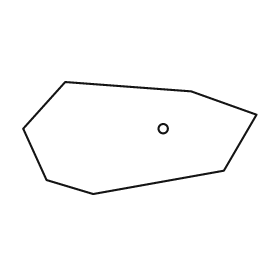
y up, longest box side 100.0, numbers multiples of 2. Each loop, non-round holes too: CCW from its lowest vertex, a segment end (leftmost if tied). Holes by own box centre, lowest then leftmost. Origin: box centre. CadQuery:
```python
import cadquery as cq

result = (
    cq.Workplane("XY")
    .moveTo(-20.0, -24.0)
    .lineTo(36.0, -14.0)
    .lineTo(50.0, 10.0)
    .lineTo(22.0, 20.0)
    .lineTo(-32.0, 24.0)
    .lineTo(-50.0, 4.0)
    .lineTo(-40.0, -18.0)
    .close()
    .moveTo(10.0, 4.0)
    .circle(2.0)
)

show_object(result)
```